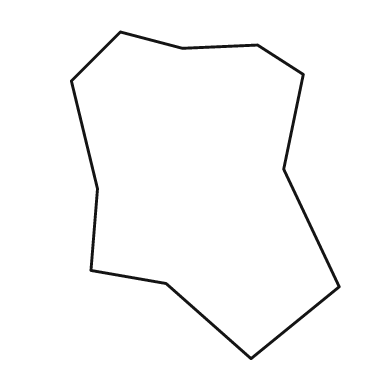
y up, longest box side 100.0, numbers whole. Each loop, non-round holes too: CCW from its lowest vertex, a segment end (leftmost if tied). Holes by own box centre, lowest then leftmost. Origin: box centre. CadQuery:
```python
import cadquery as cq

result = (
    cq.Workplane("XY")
    .moveTo(14.0, -50.0)
    .lineTo(41.0, -28.0)
    .lineTo(24.0, 8.0)
    .lineTo(30.0, 37.0)
    .lineTo(16.0, 46.0)
    .lineTo(-7.0, 45.0)
    .lineTo(-26.0, 50.0)
    .lineTo(-41.0, 35.0)
    .lineTo(-33.0, 2.0)
    .lineTo(-35.0, -23.0)
    .lineTo(-12.0, -27.0)
    .close()
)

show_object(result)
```